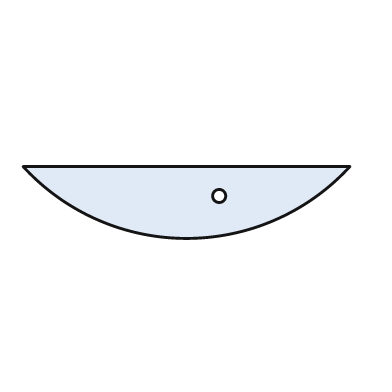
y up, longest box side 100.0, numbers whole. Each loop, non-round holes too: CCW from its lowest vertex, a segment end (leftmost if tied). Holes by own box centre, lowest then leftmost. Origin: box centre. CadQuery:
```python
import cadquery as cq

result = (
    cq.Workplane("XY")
    .moveTo(-50.0, 11.0)
    .threePointArc((0.0, -11.0), (50.0, 11.0))
    .close()
    .moveTo(10.0, 2.0)
    .circle(2.0)
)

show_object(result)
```